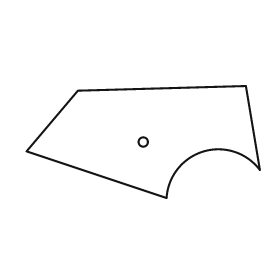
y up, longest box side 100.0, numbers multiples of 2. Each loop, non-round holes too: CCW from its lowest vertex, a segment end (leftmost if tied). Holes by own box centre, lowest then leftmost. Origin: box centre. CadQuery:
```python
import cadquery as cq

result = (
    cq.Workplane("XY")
    .moveTo(10.0, -24.0)
    .threePointArc((26.0, -4.0), (50.0, -12.0))
    .lineTo(44.0, 24.0)
    .lineTo(-28.0, 22.0)
    .lineTo(-50.0, -4.0)
    .close()
    .moveTo(0.0, 0.0)
    .circle(2.0)
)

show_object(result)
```